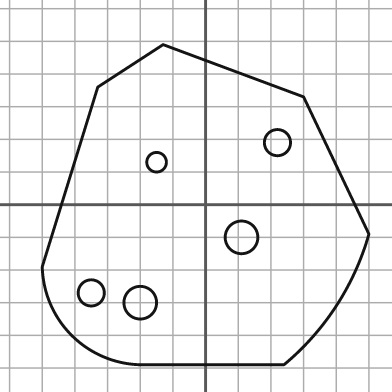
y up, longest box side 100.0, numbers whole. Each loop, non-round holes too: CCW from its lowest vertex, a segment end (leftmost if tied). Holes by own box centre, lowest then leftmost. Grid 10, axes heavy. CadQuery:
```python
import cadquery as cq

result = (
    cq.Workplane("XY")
    .moveTo(-20.0, -49.0)
    .lineTo(24.0, -49.0)
    .threePointArc((40.0, -31.0), (50.0, -9.0))
    .lineTo(30.0, 33.0)
    .lineTo(-13.0, 49.0)
    .lineTo(-33.0, 36.0)
    .lineTo(-50.0, -19.0)
    .threePointArc((-41.0, -40.0), (-20.0, -49.0))
    .close()
    .moveTo(-20.0, -30.0)
    .circle(5.0)
    .moveTo(-35.0, -27.0)
    .circle(4.0)
    .moveTo(11.0, -10.0)
    .circle(5.0)
    .moveTo(-15.0, 13.0)
    .circle(3.0)
    .moveTo(22.0, 19.0)
    .circle(4.0)
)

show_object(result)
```